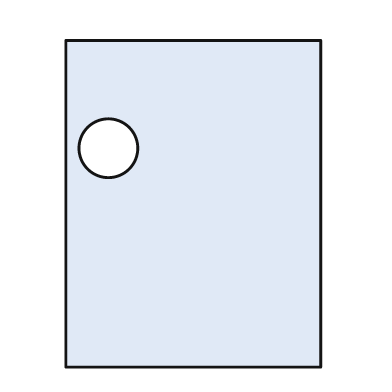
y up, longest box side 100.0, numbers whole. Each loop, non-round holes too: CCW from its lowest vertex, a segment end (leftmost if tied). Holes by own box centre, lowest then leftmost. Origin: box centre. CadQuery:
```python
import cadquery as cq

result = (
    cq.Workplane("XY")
    .moveTo(-39.0, -50.0)
    .lineTo(39.0, -50.0)
    .lineTo(39.0, 50.0)
    .lineTo(-39.0, 50.0)
    .close()
    .moveTo(-26.0, 17.0)
    .circle(9.0)
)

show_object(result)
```